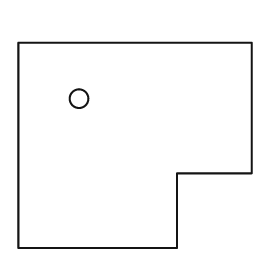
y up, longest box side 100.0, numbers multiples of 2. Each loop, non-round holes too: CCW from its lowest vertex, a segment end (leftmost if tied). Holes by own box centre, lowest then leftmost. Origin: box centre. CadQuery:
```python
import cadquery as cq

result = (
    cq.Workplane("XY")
    .moveTo(-50.0, -44.0)
    .lineTo(18.0, -44.0)
    .lineTo(18.0, -12.0)
    .lineTo(50.0, -12.0)
    .lineTo(50.0, 44.0)
    .lineTo(-50.0, 44.0)
    .close()
    .moveTo(-24.0, 20.0)
    .circle(4.0)
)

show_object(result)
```